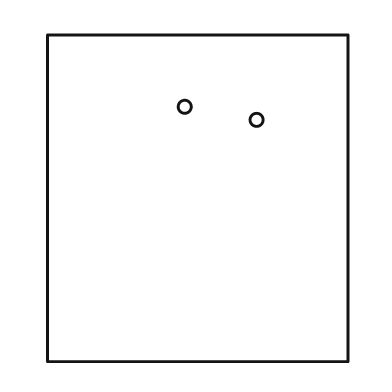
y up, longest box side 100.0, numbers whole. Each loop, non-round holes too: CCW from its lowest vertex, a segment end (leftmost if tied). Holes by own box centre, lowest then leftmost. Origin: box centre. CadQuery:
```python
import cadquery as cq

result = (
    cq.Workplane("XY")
    .moveTo(-46.0, -50.0)
    .lineTo(46.0, -50.0)
    .lineTo(46.0, 50.0)
    .lineTo(-46.0, 50.0)
    .close()
    .moveTo(18.0, 24.0)
    .circle(2.0)
    .moveTo(-4.0, 28.0)
    .circle(2.0)
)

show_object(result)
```